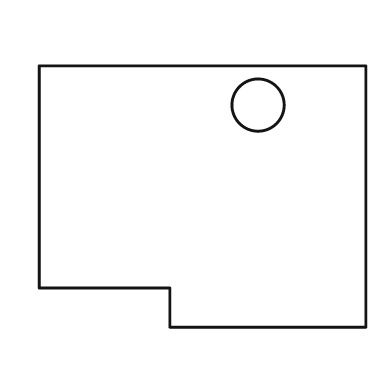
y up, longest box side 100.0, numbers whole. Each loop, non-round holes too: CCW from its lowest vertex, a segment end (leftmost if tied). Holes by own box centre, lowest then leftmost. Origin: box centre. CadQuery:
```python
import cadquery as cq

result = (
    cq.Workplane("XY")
    .moveTo(-10.0, -40.0)
    .lineTo(50.0, -40.0)
    .lineTo(50.0, 40.0)
    .lineTo(-50.0, 40.0)
    .lineTo(-50.0, -28.0)
    .lineTo(-10.0, -28.0)
    .close()
    .moveTo(17.0, 28.0)
    .circle(8.0)
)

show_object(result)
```